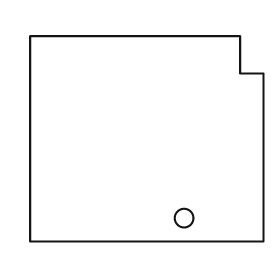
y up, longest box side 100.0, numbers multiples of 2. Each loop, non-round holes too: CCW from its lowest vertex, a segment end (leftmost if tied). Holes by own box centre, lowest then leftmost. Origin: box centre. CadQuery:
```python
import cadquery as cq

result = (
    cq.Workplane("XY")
    .moveTo(-50.0, -44.0)
    .lineTo(50.0, -44.0)
    .lineTo(50.0, 28.0)
    .lineTo(40.0, 28.0)
    .lineTo(40.0, 44.0)
    .lineTo(-50.0, 44.0)
    .close()
    .moveTo(16.0, -34.0)
    .circle(4.0)
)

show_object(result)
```